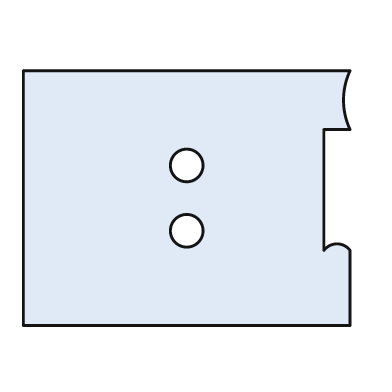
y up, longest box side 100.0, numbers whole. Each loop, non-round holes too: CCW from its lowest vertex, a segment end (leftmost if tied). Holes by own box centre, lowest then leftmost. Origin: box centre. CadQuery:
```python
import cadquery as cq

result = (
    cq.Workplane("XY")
    .moveTo(-50.0, -39.0)
    .lineTo(50.0, -39.0)
    .lineTo(50.0, -16.0)
    .threePointArc((46.0, -14.0), (42.0, -16.0))
    .lineTo(42.0, 21.0)
    .lineTo(50.0, 21.0)
    .threePointArc((48.0, 30.0), (50.0, 39.0))
    .lineTo(-50.0, 39.0)
    .close()
    .moveTo(0.0, -10.0)
    .circle(5.0)
    .moveTo(0.0, 10.0)
    .circle(5.0)
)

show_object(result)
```